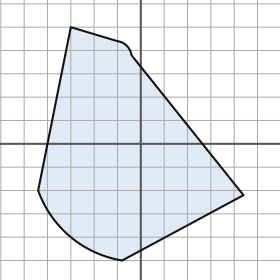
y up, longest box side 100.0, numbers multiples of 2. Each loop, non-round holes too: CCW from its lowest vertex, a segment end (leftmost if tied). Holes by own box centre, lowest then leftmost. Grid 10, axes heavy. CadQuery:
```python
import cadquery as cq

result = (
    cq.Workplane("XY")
    .moveTo(-8.0, -50.0)
    .lineTo(44.0, -22.0)
    .lineTo(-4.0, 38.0)
    .threePointArc((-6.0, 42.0), (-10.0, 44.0))
    .lineTo(-30.0, 50.0)
    .lineTo(-44.0, -20.0)
    .threePointArc((-30.0, -40.0), (-8.0, -50.0))
    .close()
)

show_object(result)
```